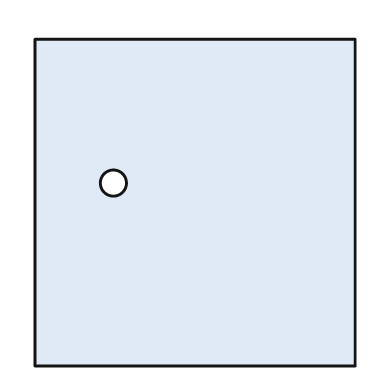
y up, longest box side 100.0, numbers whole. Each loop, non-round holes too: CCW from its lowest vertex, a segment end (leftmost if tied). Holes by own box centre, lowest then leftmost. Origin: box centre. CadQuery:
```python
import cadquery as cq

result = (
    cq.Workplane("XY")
    .moveTo(-49.0, -50.0)
    .lineTo(49.0, -50.0)
    .lineTo(49.0, 50.0)
    .lineTo(-49.0, 50.0)
    .close()
    .moveTo(-25.0, 6.0)
    .circle(4.0)
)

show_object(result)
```